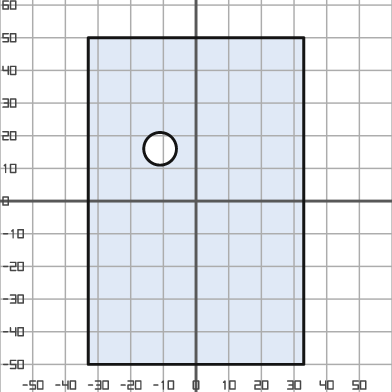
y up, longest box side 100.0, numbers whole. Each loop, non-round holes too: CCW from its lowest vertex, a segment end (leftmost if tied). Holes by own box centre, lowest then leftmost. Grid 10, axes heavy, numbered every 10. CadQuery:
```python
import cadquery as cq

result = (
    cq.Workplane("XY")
    .moveTo(-33.0, -50.0)
    .lineTo(33.0, -50.0)
    .lineTo(33.0, 50.0)
    .lineTo(-33.0, 50.0)
    .close()
    .moveTo(-11.0, 16.0)
    .circle(5.0)
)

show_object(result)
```